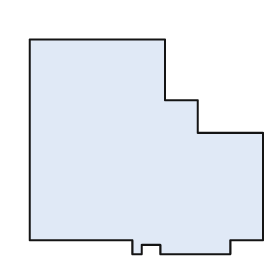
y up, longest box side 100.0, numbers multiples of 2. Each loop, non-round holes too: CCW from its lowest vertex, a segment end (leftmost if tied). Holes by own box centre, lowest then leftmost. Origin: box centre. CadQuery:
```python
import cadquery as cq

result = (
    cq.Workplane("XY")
    .moveTo(-6.0, -46.0)
    .lineTo(-2.0, -46.0)
    .lineTo(-2.0, -42.0)
    .lineTo(6.0, -42.0)
    .lineTo(6.0, -46.0)
    .lineTo(36.0, -46.0)
    .lineTo(36.0, -40.0)
    .lineTo(50.0, -40.0)
    .lineTo(50.0, 6.0)
    .lineTo(22.0, 6.0)
    .lineTo(22.0, 20.0)
    .lineTo(8.0, 20.0)
    .lineTo(8.0, 46.0)
    .lineTo(-50.0, 46.0)
    .lineTo(-50.0, -40.0)
    .lineTo(-6.0, -40.0)
    .close()
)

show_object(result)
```